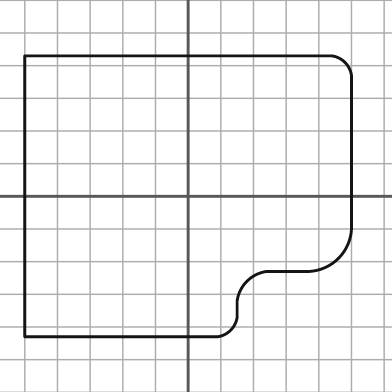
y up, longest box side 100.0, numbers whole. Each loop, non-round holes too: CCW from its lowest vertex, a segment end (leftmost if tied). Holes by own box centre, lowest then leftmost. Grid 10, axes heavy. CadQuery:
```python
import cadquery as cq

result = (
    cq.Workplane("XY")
    .moveTo(-50.0, -43.0)
    .lineTo(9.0, -43.0)
    .threePointArc((13.0, -41.0), (15.0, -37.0))
    .lineTo(15.0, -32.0)
    .threePointArc((18.0, -26.0), (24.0, -23.0))
    .lineTo(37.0, -23.0)
    .threePointArc((46.0, -19.0), (50.0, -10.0))
    .lineTo(50.0, 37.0)
    .threePointArc((48.0, 41.0), (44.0, 43.0))
    .lineTo(-50.0, 43.0)
    .close()
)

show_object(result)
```